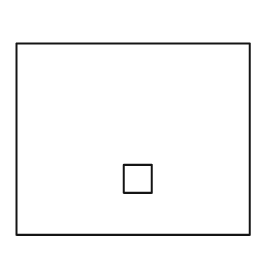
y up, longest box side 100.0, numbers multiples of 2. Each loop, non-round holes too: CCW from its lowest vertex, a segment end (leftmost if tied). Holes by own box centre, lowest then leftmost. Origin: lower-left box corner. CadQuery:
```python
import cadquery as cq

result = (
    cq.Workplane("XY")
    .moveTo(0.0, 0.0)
    .lineTo(100.0, 0.0)
    .lineTo(100.0, 82.0)
    .lineTo(0.0, 82.0)
    .close()
    .moveTo(46.0, 18.0)
    .lineTo(58.0, 18.0)
    .lineTo(58.0, 30.0)
    .lineTo(46.0, 30.0)
    .close()
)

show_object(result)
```